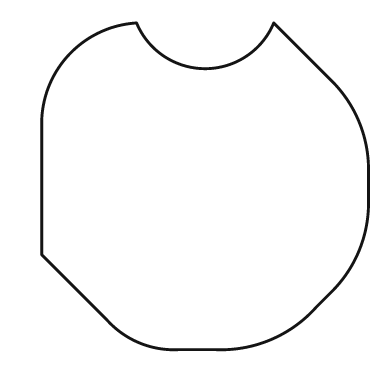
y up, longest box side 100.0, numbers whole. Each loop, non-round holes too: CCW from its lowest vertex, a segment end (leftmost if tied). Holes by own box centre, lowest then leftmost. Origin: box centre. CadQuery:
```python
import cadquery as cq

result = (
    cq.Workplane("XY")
    .moveTo(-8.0, -50.0)
    .lineTo(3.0, -50.0)
    .threePointArc((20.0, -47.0), (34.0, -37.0))
    .lineTo(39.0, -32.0)
    .threePointArc((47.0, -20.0), (50.0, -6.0))
    .lineTo(50.0, 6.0)
    .threePointArc((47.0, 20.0), (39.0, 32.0))
    .lineTo(21.0, 50.0)
    .threePointArc((0.0, 36.0), (-21.0, 50.0))
    .threePointArc((-41.0, 41.0), (-50.0, 21.0))
    .lineTo(-50.0, -21.0)
    .lineTo(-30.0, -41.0)
    .threePointArc((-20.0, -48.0), (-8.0, -50.0))
    .close()
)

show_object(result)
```